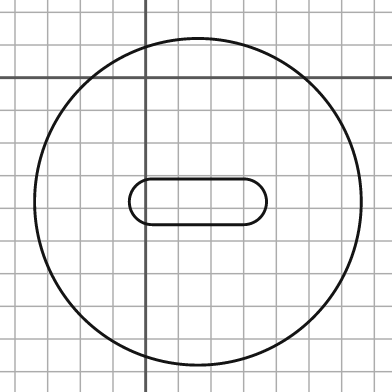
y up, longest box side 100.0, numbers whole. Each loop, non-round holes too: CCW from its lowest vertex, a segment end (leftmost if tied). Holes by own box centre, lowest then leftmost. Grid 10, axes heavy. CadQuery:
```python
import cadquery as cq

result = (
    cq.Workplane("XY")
    .moveTo(16.0, -38.0)
    .circle(50.0)
    .moveTo(2.0, -45.0)
    .lineTo(30.0, -45.0)
    .threePointArc((37.0, -38.0), (30.0, -31.0))
    .lineTo(2.0, -31.0)
    .threePointArc((-5.0, -38.0), (2.0, -45.0))
    .close()
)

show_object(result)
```